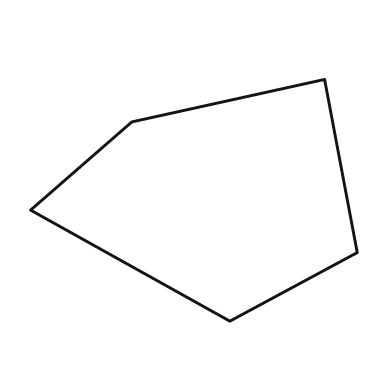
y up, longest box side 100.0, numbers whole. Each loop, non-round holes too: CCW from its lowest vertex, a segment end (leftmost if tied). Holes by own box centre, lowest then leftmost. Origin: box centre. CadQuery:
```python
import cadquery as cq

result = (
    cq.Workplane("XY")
    .moveTo(11.0, -37.0)
    .lineTo(50.0, -16.0)
    .lineTo(40.0, 37.0)
    .lineTo(-19.0, 24.0)
    .lineTo(-50.0, -3.0)
    .close()
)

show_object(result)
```